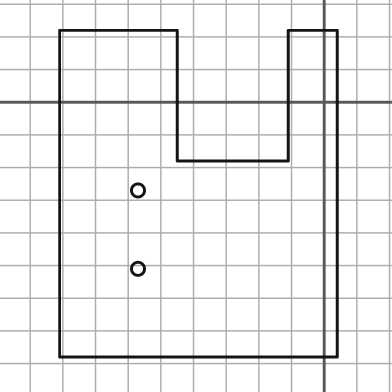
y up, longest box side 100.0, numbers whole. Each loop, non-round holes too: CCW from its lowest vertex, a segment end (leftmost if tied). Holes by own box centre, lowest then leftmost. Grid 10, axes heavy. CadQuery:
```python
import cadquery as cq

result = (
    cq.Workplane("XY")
    .moveTo(-81.0, -78.0)
    .lineTo(4.0, -78.0)
    .lineTo(4.0, 22.0)
    .lineTo(-11.0, 22.0)
    .lineTo(-11.0, -18.0)
    .lineTo(-45.0, -18.0)
    .lineTo(-45.0, 22.0)
    .lineTo(-81.0, 22.0)
    .close()
    .moveTo(-57.0, -51.0)
    .circle(2.0)
    .moveTo(-57.0, -27.0)
    .circle(2.0)
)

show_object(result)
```